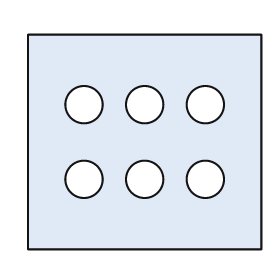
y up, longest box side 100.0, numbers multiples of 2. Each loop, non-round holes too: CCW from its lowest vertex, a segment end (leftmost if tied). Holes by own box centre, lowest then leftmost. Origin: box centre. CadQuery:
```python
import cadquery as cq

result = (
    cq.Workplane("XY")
    .moveTo(-50.0, -46.0)
    .lineTo(50.0, -46.0)
    .lineTo(50.0, 46.0)
    .lineTo(-50.0, 46.0)
    .close()
    .moveTo(-26.0, -16.0)
    .circle(8.0)
    .moveTo(0.0, -16.0)
    .circle(8.0)
    .moveTo(26.0, -16.0)
    .circle(8.0)
    .moveTo(-26.0, 16.0)
    .circle(8.0)
    .moveTo(0.0, 16.0)
    .circle(8.0)
    .moveTo(26.0, 16.0)
    .circle(8.0)
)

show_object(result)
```